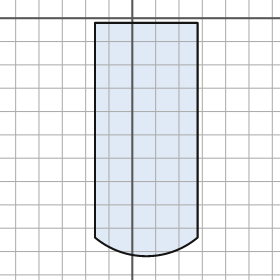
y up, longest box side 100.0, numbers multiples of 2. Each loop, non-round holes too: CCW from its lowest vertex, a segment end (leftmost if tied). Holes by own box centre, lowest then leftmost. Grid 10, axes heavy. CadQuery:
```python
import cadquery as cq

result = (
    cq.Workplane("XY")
    .moveTo(-16.0, -94.0)
    .threePointArc((6.0, -102.0), (28.0, -94.0))
    .lineTo(28.0, -2.0)
    .lineTo(-16.0, -2.0)
    .close()
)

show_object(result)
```